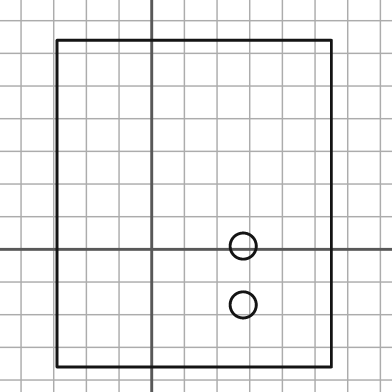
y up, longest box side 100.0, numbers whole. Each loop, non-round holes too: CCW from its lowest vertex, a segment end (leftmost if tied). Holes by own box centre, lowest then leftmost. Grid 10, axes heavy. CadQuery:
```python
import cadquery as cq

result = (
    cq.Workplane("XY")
    .moveTo(-29.0, -36.0)
    .lineTo(55.0, -36.0)
    .lineTo(55.0, 64.0)
    .lineTo(-29.0, 64.0)
    .close()
    .moveTo(28.0, -17.0)
    .circle(4.0)
    .moveTo(28.0, 1.0)
    .circle(4.0)
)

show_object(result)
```